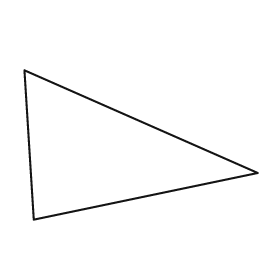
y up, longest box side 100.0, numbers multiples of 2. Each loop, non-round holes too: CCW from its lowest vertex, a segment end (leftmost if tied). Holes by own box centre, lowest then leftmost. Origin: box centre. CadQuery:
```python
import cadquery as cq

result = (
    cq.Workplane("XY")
    .moveTo(-46.0, -32.0)
    .lineTo(50.0, -12.0)
    .lineTo(-50.0, 32.0)
    .close()
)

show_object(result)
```